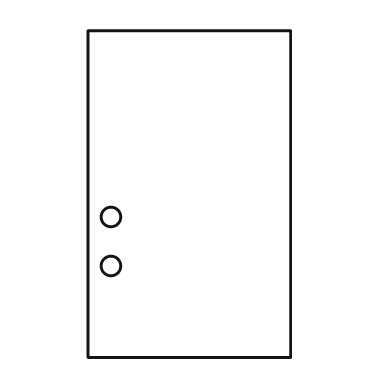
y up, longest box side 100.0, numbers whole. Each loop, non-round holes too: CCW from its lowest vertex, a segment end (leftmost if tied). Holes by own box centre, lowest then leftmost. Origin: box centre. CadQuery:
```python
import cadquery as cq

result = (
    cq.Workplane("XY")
    .moveTo(-31.0, -50.0)
    .lineTo(31.0, -50.0)
    .lineTo(31.0, 50.0)
    .lineTo(-31.0, 50.0)
    .close()
    .moveTo(-24.0, -22.0)
    .circle(3.0)
    .moveTo(-24.0, -7.0)
    .circle(3.0)
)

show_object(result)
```